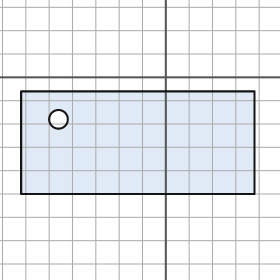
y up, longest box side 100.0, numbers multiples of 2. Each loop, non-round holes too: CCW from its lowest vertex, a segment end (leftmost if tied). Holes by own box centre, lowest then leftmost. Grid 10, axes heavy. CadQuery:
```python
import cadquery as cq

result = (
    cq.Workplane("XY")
    .moveTo(-62.0, -50.0)
    .lineTo(38.0, -50.0)
    .lineTo(38.0, -6.0)
    .lineTo(-62.0, -6.0)
    .close()
    .moveTo(-46.0, -18.0)
    .circle(4.0)
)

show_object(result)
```